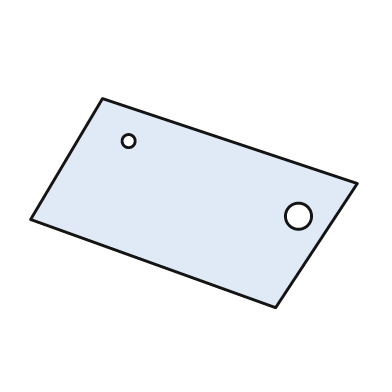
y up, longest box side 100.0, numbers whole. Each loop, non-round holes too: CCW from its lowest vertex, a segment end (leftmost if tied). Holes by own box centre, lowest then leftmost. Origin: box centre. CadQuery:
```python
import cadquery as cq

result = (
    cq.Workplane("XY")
    .moveTo(25.0, -32.0)
    .lineTo(50.0, 6.0)
    .lineTo(-28.0, 32.0)
    .lineTo(-50.0, -5.0)
    .close()
    .moveTo(32.0, -4.0)
    .circle(4.0)
    .moveTo(-20.0, 19.0)
    .circle(2.0)
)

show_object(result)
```